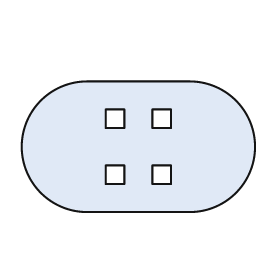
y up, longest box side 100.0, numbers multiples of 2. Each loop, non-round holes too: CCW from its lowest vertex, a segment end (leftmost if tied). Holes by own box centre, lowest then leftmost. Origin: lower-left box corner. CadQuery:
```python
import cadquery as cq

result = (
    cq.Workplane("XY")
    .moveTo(28.0, 0.0)
    .lineTo(72.0, 0.0)
    .threePointArc((100.0, 28.0), (72.0, 56.0))
    .lineTo(28.0, 56.0)
    .threePointArc((0.0, 28.0), (28.0, 0.0))
    .close()
    .moveTo(36.0, 12.0)
    .lineTo(44.0, 12.0)
    .lineTo(44.0, 20.0)
    .lineTo(36.0, 20.0)
    .close()
    .moveTo(56.0, 12.0)
    .lineTo(64.0, 12.0)
    .lineTo(64.0, 20.0)
    .lineTo(56.0, 20.0)
    .close()
    .moveTo(36.0, 36.0)
    .lineTo(44.0, 36.0)
    .lineTo(44.0, 44.0)
    .lineTo(36.0, 44.0)
    .close()
    .moveTo(56.0, 36.0)
    .lineTo(64.0, 36.0)
    .lineTo(64.0, 44.0)
    .lineTo(56.0, 44.0)
    .close()
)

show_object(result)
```